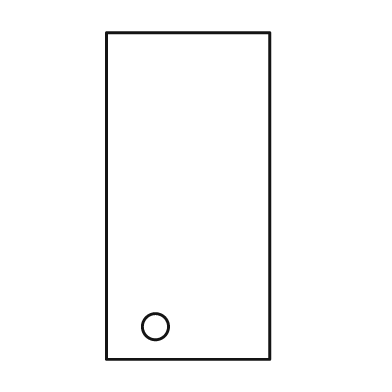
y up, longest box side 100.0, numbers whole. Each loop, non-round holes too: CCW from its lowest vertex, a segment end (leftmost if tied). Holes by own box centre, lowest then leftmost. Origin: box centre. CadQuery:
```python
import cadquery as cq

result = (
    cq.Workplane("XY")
    .moveTo(-25.0, -50.0)
    .lineTo(25.0, -50.0)
    .lineTo(25.0, 50.0)
    .lineTo(-25.0, 50.0)
    .close()
    .moveTo(-10.0, -40.0)
    .circle(4.0)
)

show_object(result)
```